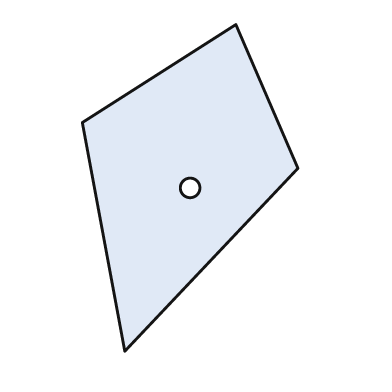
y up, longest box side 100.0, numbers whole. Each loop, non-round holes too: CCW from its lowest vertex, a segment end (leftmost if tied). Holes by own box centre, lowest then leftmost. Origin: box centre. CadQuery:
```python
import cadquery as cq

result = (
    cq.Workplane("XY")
    .moveTo(-20.0, -50.0)
    .lineTo(33.0, 6.0)
    .lineTo(14.0, 50.0)
    .lineTo(-33.0, 20.0)
    .close()
    .moveTo(0.0, 0.0)
    .circle(3.0)
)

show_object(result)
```